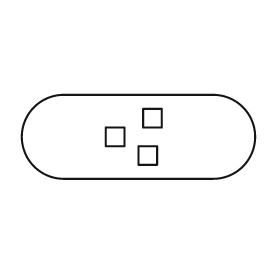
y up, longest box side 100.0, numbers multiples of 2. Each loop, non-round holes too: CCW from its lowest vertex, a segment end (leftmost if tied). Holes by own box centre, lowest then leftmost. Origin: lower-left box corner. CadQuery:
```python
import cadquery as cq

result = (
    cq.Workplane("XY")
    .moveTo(18.0, 0.0)
    .lineTo(82.0, 0.0)
    .threePointArc((100.0, 18.0), (82.0, 36.0))
    .lineTo(18.0, 36.0)
    .threePointArc((0.0, 18.0), (18.0, 0.0))
    .close()
    .moveTo(50.0, 6.0)
    .lineTo(58.0, 6.0)
    .lineTo(58.0, 14.0)
    .lineTo(50.0, 14.0)
    .close()
    .moveTo(36.0, 14.0)
    .lineTo(44.0, 14.0)
    .lineTo(44.0, 22.0)
    .lineTo(36.0, 22.0)
    .close()
    .moveTo(52.0, 22.0)
    .lineTo(60.0, 22.0)
    .lineTo(60.0, 30.0)
    .lineTo(52.0, 30.0)
    .close()
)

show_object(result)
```